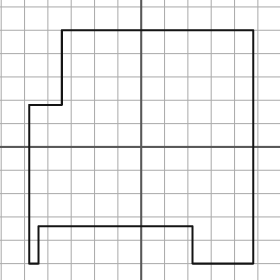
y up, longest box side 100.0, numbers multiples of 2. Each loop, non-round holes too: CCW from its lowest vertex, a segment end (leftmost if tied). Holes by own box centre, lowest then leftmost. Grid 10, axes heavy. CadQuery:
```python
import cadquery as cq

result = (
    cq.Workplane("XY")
    .moveTo(-48.0, -50.0)
    .lineTo(-44.0, -50.0)
    .lineTo(-44.0, -34.0)
    .lineTo(22.0, -34.0)
    .lineTo(22.0, -50.0)
    .lineTo(48.0, -50.0)
    .lineTo(48.0, 50.0)
    .lineTo(-34.0, 50.0)
    .lineTo(-34.0, 18.0)
    .lineTo(-48.0, 18.0)
    .close()
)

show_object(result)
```